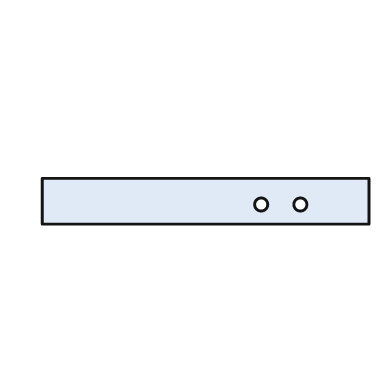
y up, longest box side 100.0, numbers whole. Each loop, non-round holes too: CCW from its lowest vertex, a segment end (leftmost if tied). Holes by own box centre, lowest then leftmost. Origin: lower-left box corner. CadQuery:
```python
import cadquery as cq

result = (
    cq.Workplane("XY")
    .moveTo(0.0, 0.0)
    .lineTo(100.0, 0.0)
    .lineTo(100.0, 14.0)
    .lineTo(0.0, 14.0)
    .close()
    .moveTo(67.0, 6.0)
    .circle(2.0)
    .moveTo(79.0, 6.0)
    .circle(2.0)
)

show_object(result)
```